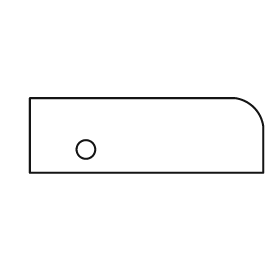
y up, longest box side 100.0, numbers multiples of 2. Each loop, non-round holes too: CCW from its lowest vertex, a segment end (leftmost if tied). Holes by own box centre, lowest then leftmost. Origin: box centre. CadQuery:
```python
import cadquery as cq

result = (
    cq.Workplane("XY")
    .moveTo(-50.0, -16.0)
    .lineTo(50.0, -16.0)
    .lineTo(50.0, 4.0)
    .threePointArc((46.0, 12.0), (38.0, 16.0))
    .lineTo(-50.0, 16.0)
    .close()
    .moveTo(-26.0, -6.0)
    .circle(4.0)
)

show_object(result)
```